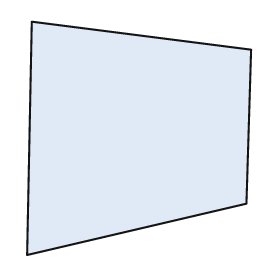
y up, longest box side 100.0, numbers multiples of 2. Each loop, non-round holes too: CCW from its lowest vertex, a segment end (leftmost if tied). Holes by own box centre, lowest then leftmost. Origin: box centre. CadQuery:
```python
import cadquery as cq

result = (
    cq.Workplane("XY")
    .moveTo(-48.0, -50.0)
    .lineTo(46.0, -28.0)
    .lineTo(48.0, 38.0)
    .lineTo(-46.0, 50.0)
    .close()
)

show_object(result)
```